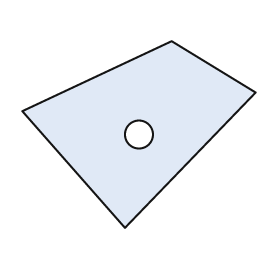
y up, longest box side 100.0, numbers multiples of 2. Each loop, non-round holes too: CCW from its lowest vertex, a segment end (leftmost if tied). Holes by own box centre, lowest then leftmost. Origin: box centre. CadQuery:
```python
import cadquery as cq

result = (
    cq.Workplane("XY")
    .moveTo(-6.0, -40.0)
    .lineTo(50.0, 18.0)
    .lineTo(14.0, 40.0)
    .lineTo(-50.0, 10.0)
    .close()
    .moveTo(0.0, 0.0)
    .circle(6.0)
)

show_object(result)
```